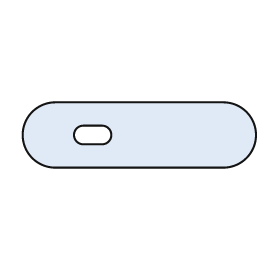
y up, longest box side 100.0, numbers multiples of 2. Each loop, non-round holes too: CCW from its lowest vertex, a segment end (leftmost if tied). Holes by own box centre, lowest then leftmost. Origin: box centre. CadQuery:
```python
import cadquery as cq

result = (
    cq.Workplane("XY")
    .moveTo(-36.0, -14.0)
    .lineTo(36.0, -14.0)
    .threePointArc((50.0, 0.0), (36.0, 14.0))
    .lineTo(-36.0, 14.0)
    .threePointArc((-50.0, 0.0), (-36.0, -14.0))
    .close()
    .moveTo(-24.0, -4.0)
    .lineTo(-16.0, -4.0)
    .threePointArc((-12.0, 0.0), (-16.0, 4.0))
    .lineTo(-24.0, 4.0)
    .threePointArc((-28.0, 0.0), (-24.0, -4.0))
    .close()
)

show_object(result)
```